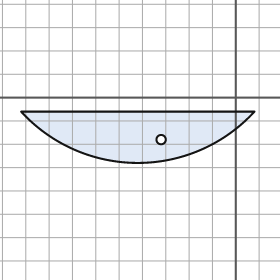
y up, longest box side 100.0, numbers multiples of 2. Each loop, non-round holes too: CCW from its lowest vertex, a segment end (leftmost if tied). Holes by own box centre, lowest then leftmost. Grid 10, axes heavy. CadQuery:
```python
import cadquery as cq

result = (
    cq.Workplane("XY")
    .moveTo(-92.0, -6.0)
    .threePointArc((-42.0, -28.0), (8.0, -6.0))
    .close()
    .moveTo(-32.0, -18.0)
    .circle(2.0)
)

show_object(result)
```